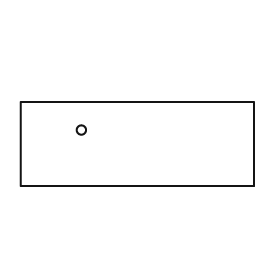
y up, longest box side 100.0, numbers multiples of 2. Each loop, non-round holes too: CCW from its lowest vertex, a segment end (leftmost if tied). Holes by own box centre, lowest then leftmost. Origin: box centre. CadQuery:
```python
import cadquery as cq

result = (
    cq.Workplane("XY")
    .moveTo(-50.0, -18.0)
    .lineTo(50.0, -18.0)
    .lineTo(50.0, 18.0)
    .lineTo(-50.0, 18.0)
    .close()
    .moveTo(-24.0, 6.0)
    .circle(2.0)
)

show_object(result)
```